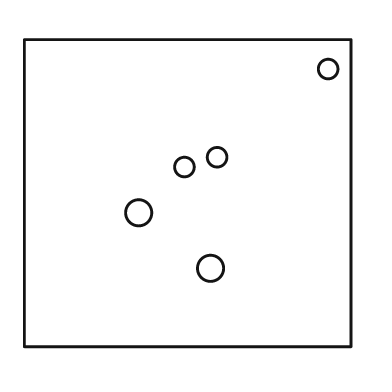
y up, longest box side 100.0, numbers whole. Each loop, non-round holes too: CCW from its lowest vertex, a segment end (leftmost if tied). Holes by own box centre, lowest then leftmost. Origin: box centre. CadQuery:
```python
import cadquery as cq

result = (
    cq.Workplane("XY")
    .moveTo(-50.0, -47.0)
    .lineTo(50.0, -47.0)
    .lineTo(50.0, 47.0)
    .lineTo(-50.0, 47.0)
    .close()
    .moveTo(7.0, -23.0)
    .circle(4.0)
    .moveTo(-15.0, -6.0)
    .circle(4.0)
    .moveTo(-1.0, 8.0)
    .circle(3.0)
    .moveTo(9.0, 11.0)
    .circle(3.0)
    .moveTo(43.0, 38.0)
    .circle(3.0)
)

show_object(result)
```